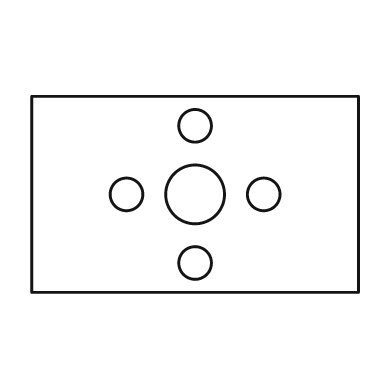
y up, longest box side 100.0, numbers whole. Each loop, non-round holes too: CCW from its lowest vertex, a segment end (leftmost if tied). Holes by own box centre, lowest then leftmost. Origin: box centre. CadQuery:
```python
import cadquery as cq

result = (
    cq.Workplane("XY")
    .moveTo(-50.0, -30.0)
    .lineTo(50.0, -30.0)
    .lineTo(50.0, 30.0)
    .lineTo(-50.0, 30.0)
    .close()
    .moveTo(0.0, -21.0)
    .circle(5.0)
    .moveTo(-21.0, 0.0)
    .circle(5.0)
    .moveTo(0.0, 0.0)
    .circle(9.0)
    .moveTo(21.0, 0.0)
    .circle(5.0)
    .moveTo(0.0, 21.0)
    .circle(5.0)
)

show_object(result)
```